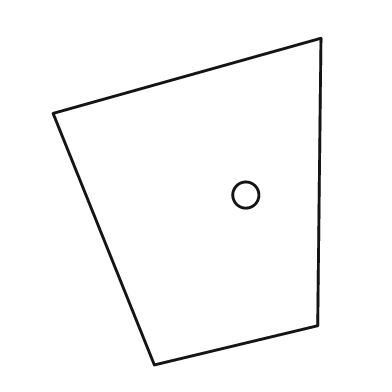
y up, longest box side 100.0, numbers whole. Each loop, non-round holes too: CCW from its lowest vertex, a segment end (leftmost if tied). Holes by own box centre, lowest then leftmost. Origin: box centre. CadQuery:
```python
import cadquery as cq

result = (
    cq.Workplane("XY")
    .moveTo(-10.0, -50.0)
    .lineTo(40.0, -38.0)
    .lineTo(41.0, 50.0)
    .lineTo(-41.0, 27.0)
    .close()
    .moveTo(18.0, 2.0)
    .circle(4.0)
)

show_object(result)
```